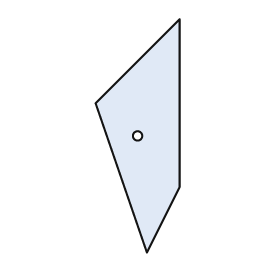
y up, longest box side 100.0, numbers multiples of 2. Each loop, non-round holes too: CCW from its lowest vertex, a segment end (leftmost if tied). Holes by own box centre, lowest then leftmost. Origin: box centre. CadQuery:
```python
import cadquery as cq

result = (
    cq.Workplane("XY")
    .moveTo(4.0, -50.0)
    .lineTo(18.0, -22.0)
    .lineTo(18.0, 50.0)
    .lineTo(-18.0, 14.0)
    .close()
    .moveTo(0.0, 0.0)
    .circle(2.0)
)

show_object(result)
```